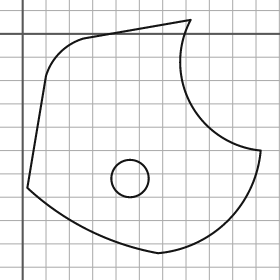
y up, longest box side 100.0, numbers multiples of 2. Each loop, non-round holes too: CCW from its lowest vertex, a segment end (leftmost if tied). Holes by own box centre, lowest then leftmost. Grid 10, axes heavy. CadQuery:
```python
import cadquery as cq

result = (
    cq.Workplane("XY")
    .moveTo(58.0, -94.0)
    .threePointArc((88.0, -80.0), (102.0, -50.0))
    .threePointArc((72.0, -30.0), (72.0, 6.0))
    .lineTo(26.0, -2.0)
    .threePointArc((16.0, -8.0), (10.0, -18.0))
    .lineTo(2.0, -66.0)
    .threePointArc((28.0, -84.0), (58.0, -94.0))
    .close()
    .moveTo(46.0, -62.0)
    .circle(8.0)
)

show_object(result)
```